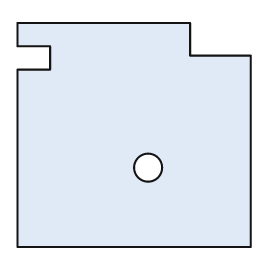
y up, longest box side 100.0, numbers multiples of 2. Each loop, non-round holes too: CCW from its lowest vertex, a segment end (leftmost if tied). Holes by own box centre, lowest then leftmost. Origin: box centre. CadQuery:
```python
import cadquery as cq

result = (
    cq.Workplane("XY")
    .moveTo(-50.0, -48.0)
    .lineTo(50.0, -48.0)
    .lineTo(50.0, 34.0)
    .lineTo(24.0, 34.0)
    .lineTo(24.0, 48.0)
    .lineTo(-50.0, 48.0)
    .lineTo(-50.0, 38.0)
    .lineTo(-36.0, 38.0)
    .lineTo(-36.0, 28.0)
    .lineTo(-50.0, 28.0)
    .close()
    .moveTo(6.0, -14.0)
    .circle(6.0)
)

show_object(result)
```